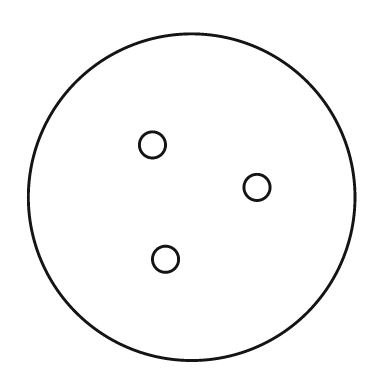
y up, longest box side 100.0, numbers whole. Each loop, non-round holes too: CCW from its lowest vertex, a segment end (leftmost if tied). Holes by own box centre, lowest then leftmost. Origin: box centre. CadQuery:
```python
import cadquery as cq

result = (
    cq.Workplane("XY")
    .moveTo(0.0, 0.0)
    .circle(50.0)
    .moveTo(-8.0, -19.0)
    .circle(4.0)
    .moveTo(20.0, 3.0)
    .circle(4.0)
    .moveTo(-12.0, 16.0)
    .circle(4.0)
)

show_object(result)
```